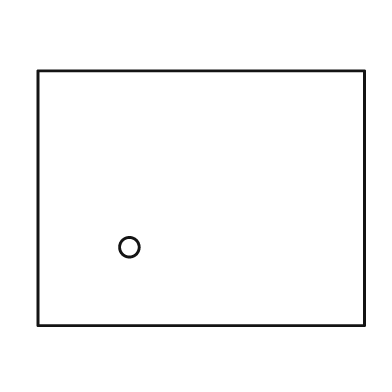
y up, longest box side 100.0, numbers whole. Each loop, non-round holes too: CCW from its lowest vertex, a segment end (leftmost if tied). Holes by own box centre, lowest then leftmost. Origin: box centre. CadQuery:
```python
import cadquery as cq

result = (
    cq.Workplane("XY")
    .moveTo(-50.0, -39.0)
    .lineTo(50.0, -39.0)
    .lineTo(50.0, 39.0)
    .lineTo(-50.0, 39.0)
    .close()
    .moveTo(-22.0, -15.0)
    .circle(3.0)
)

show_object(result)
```